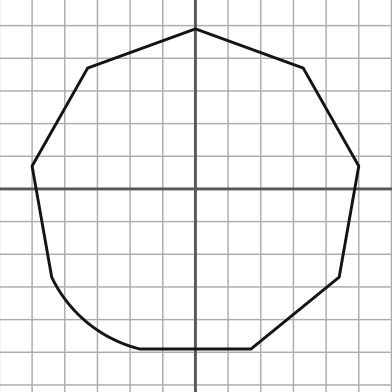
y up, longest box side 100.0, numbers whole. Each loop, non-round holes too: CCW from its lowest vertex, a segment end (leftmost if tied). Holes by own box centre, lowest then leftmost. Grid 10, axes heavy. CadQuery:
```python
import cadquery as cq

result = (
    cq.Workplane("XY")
    .moveTo(-17.0, -49.0)
    .lineTo(17.0, -49.0)
    .lineTo(44.0, -27.0)
    .lineTo(50.0, 7.0)
    .lineTo(33.0, 37.0)
    .lineTo(0.0, 49.0)
    .lineTo(-33.0, 37.0)
    .lineTo(-50.0, 7.0)
    .lineTo(-44.0, -27.0)
    .threePointArc((-33.0, -41.0), (-17.0, -49.0))
    .close()
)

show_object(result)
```